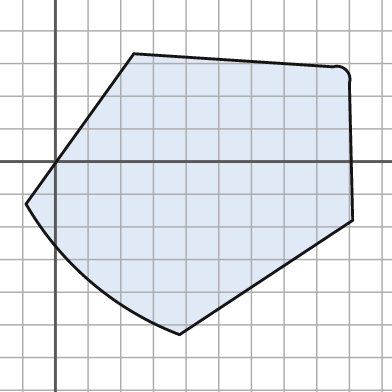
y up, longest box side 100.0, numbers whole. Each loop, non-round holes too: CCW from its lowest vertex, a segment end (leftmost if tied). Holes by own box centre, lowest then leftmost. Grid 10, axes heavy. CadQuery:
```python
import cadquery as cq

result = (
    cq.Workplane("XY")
    .moveTo(38.0, -53.0)
    .lineTo(91.0, -18.0)
    .lineTo(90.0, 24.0)
    .threePointArc((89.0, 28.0), (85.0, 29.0))
    .lineTo(24.0, 33.0)
    .lineTo(-9.0, -13.0)
    .threePointArc((11.0, -37.0), (38.0, -53.0))
    .close()
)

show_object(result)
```